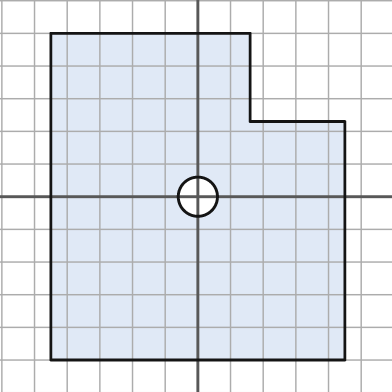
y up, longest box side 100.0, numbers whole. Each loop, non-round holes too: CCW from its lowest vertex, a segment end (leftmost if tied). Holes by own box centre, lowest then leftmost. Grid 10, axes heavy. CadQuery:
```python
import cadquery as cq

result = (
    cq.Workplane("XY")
    .moveTo(-45.0, -50.0)
    .lineTo(45.0, -50.0)
    .lineTo(45.0, 23.0)
    .lineTo(16.0, 23.0)
    .lineTo(16.0, 50.0)
    .lineTo(-45.0, 50.0)
    .close()
    .moveTo(0.0, 0.0)
    .circle(6.0)
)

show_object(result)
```